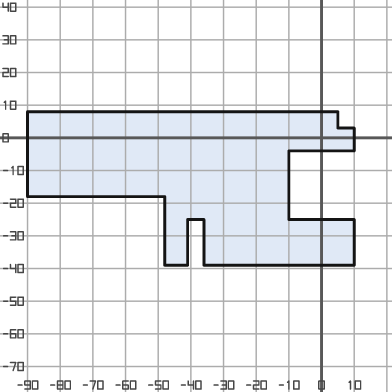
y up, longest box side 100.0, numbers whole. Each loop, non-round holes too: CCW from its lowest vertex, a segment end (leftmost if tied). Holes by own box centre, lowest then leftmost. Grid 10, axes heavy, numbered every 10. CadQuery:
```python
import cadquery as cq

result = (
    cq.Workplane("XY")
    .moveTo(-48.0, -39.0)
    .lineTo(-41.0, -39.0)
    .lineTo(-41.0, -25.0)
    .lineTo(-36.0, -25.0)
    .lineTo(-36.0, -39.0)
    .lineTo(10.0, -39.0)
    .lineTo(10.0, -25.0)
    .lineTo(-10.0, -25.0)
    .lineTo(-10.0, -4.0)
    .lineTo(10.0, -4.0)
    .lineTo(10.0, 3.0)
    .lineTo(5.0, 3.0)
    .lineTo(5.0, 8.0)
    .lineTo(-90.0, 8.0)
    .lineTo(-90.0, -18.0)
    .lineTo(-48.0, -18.0)
    .close()
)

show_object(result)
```